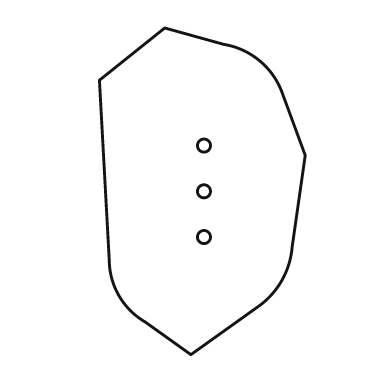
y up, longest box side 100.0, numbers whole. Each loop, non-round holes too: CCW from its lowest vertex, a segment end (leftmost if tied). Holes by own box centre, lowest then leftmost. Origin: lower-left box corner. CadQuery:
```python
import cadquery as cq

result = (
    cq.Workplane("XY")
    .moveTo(28.0, 0.0)
    .lineTo(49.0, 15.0)
    .threePointArc((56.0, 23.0), (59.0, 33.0))
    .lineTo(63.0, 61.0)
    .lineTo(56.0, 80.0)
    .threePointArc((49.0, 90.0), (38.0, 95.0))
    .lineTo(20.0, 100.0)
    .lineTo(0.0, 84.0)
    .lineTo(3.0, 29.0)
    .threePointArc((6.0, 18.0), (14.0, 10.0))
    .close()
    .moveTo(32.0, 36.0)
    .circle(2.0)
    .moveTo(32.0, 50.0)
    .circle(2.0)
    .moveTo(32.0, 64.0)
    .circle(2.0)
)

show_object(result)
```